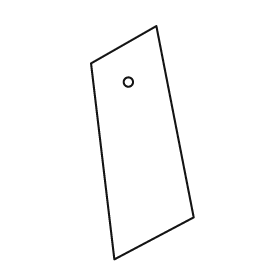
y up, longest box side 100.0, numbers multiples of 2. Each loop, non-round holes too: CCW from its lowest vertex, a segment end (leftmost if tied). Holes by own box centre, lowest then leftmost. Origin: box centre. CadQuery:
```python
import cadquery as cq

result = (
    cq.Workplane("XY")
    .moveTo(-12.0, -50.0)
    .lineTo(22.0, -32.0)
    .lineTo(6.0, 50.0)
    .lineTo(-22.0, 34.0)
    .close()
    .moveTo(-6.0, 26.0)
    .circle(2.0)
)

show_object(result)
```